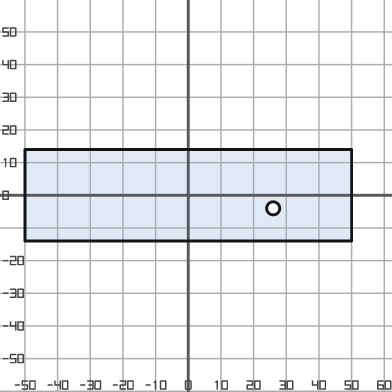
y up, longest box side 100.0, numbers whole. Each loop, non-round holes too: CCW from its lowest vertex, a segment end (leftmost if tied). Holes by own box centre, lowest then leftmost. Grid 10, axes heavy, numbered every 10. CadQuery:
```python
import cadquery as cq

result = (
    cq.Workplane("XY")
    .moveTo(-50.0, -14.0)
    .lineTo(50.0, -14.0)
    .lineTo(50.0, 14.0)
    .lineTo(-50.0, 14.0)
    .close()
    .moveTo(26.0, -4.0)
    .circle(2.0)
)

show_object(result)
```